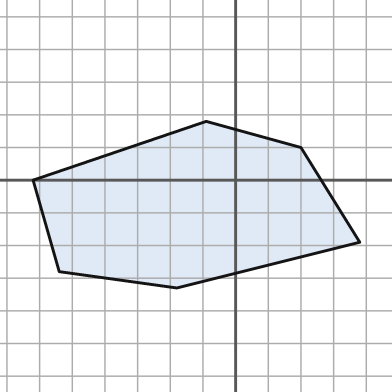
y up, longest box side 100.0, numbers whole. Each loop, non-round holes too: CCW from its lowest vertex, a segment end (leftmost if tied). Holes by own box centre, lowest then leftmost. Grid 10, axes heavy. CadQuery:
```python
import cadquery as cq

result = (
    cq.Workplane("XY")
    .moveTo(-18.0, -33.0)
    .lineTo(38.0, -19.0)
    .lineTo(20.0, 10.0)
    .lineTo(-9.0, 18.0)
    .lineTo(-62.0, 0.0)
    .lineTo(-54.0, -28.0)
    .close()
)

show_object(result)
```